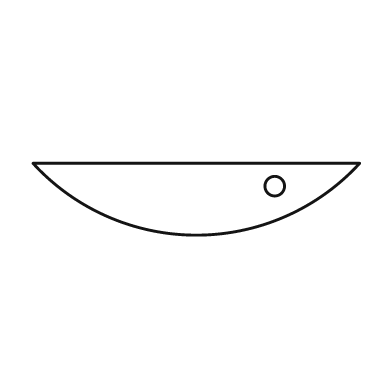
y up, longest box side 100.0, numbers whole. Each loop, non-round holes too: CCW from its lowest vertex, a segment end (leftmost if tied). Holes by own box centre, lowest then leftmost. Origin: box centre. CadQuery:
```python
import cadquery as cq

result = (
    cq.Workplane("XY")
    .moveTo(-50.0, 11.0)
    .threePointArc((0.0, -11.0), (50.0, 11.0))
    .close()
    .moveTo(24.0, 4.0)
    .circle(3.0)
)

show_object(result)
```